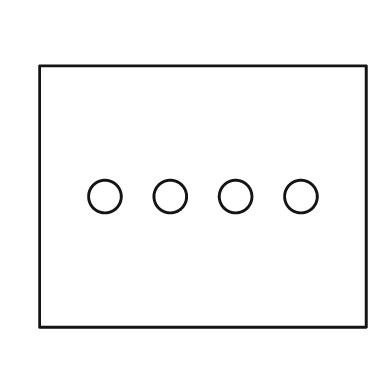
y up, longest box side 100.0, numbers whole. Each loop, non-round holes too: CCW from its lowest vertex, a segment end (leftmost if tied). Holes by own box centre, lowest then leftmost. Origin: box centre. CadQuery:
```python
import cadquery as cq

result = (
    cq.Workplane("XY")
    .moveTo(-50.0, -40.0)
    .lineTo(50.0, -40.0)
    .lineTo(50.0, 40.0)
    .lineTo(-50.0, 40.0)
    .close()
    .moveTo(-30.0, 0.0)
    .circle(5.0)
    .moveTo(-10.0, 0.0)
    .circle(5.0)
    .moveTo(10.0, 0.0)
    .circle(5.0)
    .moveTo(30.0, 0.0)
    .circle(5.0)
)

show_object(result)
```